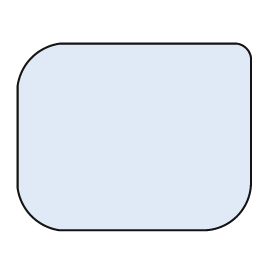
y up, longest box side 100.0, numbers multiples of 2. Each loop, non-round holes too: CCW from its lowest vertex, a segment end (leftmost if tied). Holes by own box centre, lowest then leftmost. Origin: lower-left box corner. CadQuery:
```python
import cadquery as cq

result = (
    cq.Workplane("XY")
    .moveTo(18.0, 0.0)
    .lineTo(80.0, 0.0)
    .threePointArc((94.0, 6.0), (100.0, 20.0))
    .lineTo(100.0, 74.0)
    .threePointArc((98.0, 78.0), (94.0, 80.0))
    .lineTo(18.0, 80.0)
    .threePointArc((6.0, 74.0), (0.0, 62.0))
    .lineTo(0.0, 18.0)
    .threePointArc((6.0, 6.0), (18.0, 0.0))
    .close()
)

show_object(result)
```